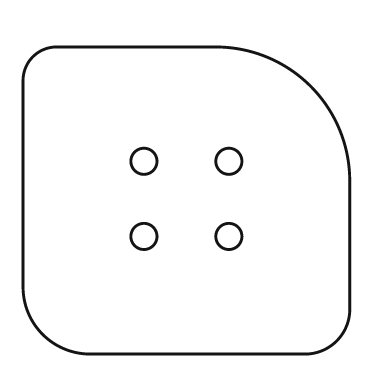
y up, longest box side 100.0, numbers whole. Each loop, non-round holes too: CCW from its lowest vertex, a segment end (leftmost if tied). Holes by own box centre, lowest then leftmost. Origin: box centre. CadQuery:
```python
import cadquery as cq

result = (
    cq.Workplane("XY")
    .moveTo(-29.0, -47.0)
    .lineTo(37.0, -47.0)
    .threePointArc((46.0, -43.0), (50.0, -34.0))
    .lineTo(50.0, 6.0)
    .threePointArc((38.0, 35.0), (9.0, 47.0))
    .lineTo(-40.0, 47.0)
    .threePointArc((-47.0, 44.0), (-50.0, 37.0))
    .lineTo(-50.0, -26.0)
    .threePointArc((-44.0, -41.0), (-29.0, -47.0))
    .close()
    .moveTo(-13.0, -11.0)
    .circle(4.0)
    .moveTo(13.0, -11.0)
    .circle(4.0)
    .moveTo(-13.0, 12.0)
    .circle(4.0)
    .moveTo(13.0, 12.0)
    .circle(4.0)
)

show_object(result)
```